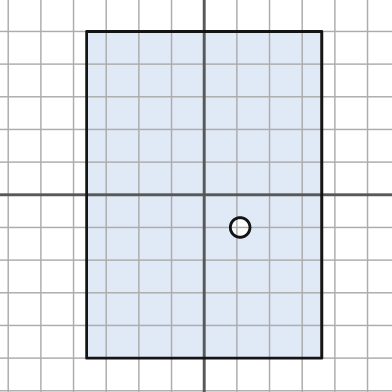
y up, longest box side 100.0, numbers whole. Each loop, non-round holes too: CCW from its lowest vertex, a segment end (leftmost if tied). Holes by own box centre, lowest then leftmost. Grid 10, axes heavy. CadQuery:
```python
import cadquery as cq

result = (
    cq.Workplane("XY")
    .moveTo(-36.0, -50.0)
    .lineTo(36.0, -50.0)
    .lineTo(36.0, 50.0)
    .lineTo(-36.0, 50.0)
    .close()
    .moveTo(11.0, -10.0)
    .circle(3.0)
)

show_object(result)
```